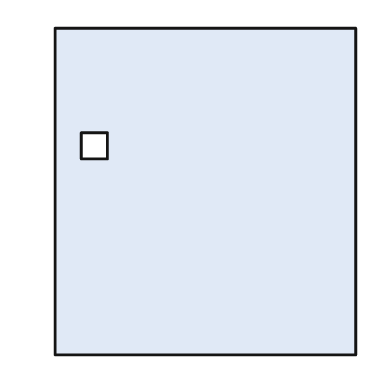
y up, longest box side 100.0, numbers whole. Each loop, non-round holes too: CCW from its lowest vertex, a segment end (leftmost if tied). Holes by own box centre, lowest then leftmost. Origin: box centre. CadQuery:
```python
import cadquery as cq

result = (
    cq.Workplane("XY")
    .moveTo(-46.0, -50.0)
    .lineTo(46.0, -50.0)
    .lineTo(46.0, 50.0)
    .lineTo(-46.0, 50.0)
    .close()
    .moveTo(-38.0, 10.0)
    .lineTo(-30.0, 10.0)
    .lineTo(-30.0, 18.0)
    .lineTo(-38.0, 18.0)
    .close()
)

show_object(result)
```